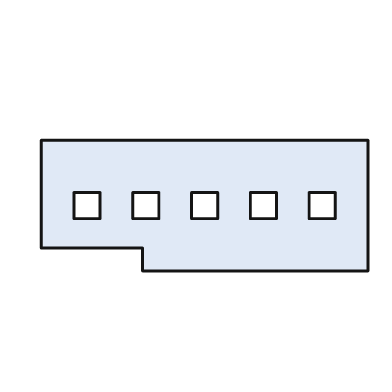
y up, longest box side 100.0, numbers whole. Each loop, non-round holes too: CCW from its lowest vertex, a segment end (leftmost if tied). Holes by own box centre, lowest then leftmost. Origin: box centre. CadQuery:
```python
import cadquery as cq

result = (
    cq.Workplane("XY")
    .moveTo(-19.0, -20.0)
    .lineTo(50.0, -20.0)
    .lineTo(50.0, 20.0)
    .lineTo(-50.0, 20.0)
    .lineTo(-50.0, -13.0)
    .lineTo(-19.0, -13.0)
    .close()
    .moveTo(-40.0, -4.0)
    .lineTo(-32.0, -4.0)
    .lineTo(-32.0, 4.0)
    .lineTo(-40.0, 4.0)
    .close()
    .moveTo(-22.0, -4.0)
    .lineTo(-14.0, -4.0)
    .lineTo(-14.0, 4.0)
    .lineTo(-22.0, 4.0)
    .close()
    .moveTo(-4.0, -4.0)
    .lineTo(4.0, -4.0)
    .lineTo(4.0, 4.0)
    .lineTo(-4.0, 4.0)
    .close()
    .moveTo(14.0, -4.0)
    .lineTo(22.0, -4.0)
    .lineTo(22.0, 4.0)
    .lineTo(14.0, 4.0)
    .close()
    .moveTo(32.0, -4.0)
    .lineTo(40.0, -4.0)
    .lineTo(40.0, 4.0)
    .lineTo(32.0, 4.0)
    .close()
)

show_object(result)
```